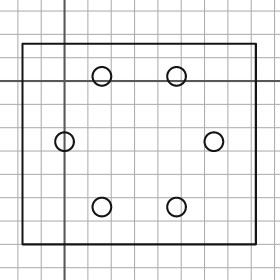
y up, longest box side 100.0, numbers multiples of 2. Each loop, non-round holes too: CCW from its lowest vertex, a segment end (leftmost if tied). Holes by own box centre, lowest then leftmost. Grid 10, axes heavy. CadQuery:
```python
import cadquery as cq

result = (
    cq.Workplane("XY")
    .moveTo(-18.0, -70.0)
    .lineTo(82.0, -70.0)
    .lineTo(82.0, 16.0)
    .lineTo(-18.0, 16.0)
    .close()
    .moveTo(16.0, -54.0)
    .circle(4.0)
    .moveTo(48.0, -54.0)
    .circle(4.0)
    .moveTo(0.0, -26.0)
    .circle(4.0)
    .moveTo(64.0, -26.0)
    .circle(4.0)
    .moveTo(16.0, 2.0)
    .circle(4.0)
    .moveTo(48.0, 2.0)
    .circle(4.0)
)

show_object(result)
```